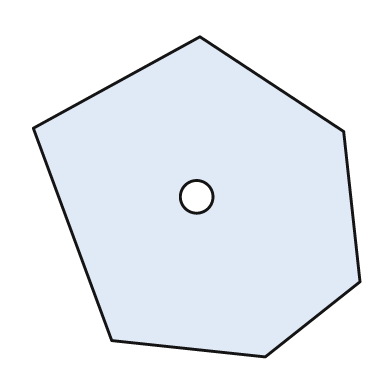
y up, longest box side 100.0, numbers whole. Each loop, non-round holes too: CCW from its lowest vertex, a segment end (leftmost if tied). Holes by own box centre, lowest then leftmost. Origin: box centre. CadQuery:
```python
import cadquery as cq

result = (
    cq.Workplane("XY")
    .moveTo(21.0, -49.0)
    .lineTo(50.0, -26.0)
    .lineTo(45.0, 20.0)
    .lineTo(1.0, 49.0)
    .lineTo(-50.0, 21.0)
    .lineTo(-26.0, -44.0)
    .close()
    .moveTo(0.0, 0.0)
    .circle(5.0)
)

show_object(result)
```